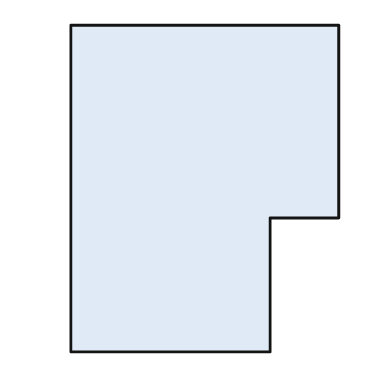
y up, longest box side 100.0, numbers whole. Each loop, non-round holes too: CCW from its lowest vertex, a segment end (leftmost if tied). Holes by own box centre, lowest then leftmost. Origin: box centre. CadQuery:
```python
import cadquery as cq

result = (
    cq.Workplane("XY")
    .moveTo(-41.0, -50.0)
    .lineTo(20.0, -50.0)
    .lineTo(20.0, -9.0)
    .lineTo(41.0, -9.0)
    .lineTo(41.0, 50.0)
    .lineTo(-41.0, 50.0)
    .close()
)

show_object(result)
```